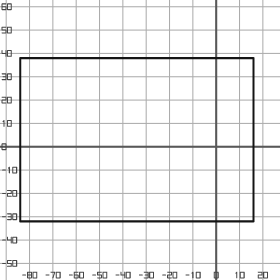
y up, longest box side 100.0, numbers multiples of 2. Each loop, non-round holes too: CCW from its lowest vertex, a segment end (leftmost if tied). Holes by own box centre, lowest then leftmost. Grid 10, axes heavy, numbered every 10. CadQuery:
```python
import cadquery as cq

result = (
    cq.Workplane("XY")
    .moveTo(-84.0, -32.0)
    .lineTo(16.0, -32.0)
    .lineTo(16.0, 38.0)
    .lineTo(-84.0, 38.0)
    .close()
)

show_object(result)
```